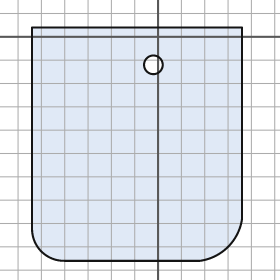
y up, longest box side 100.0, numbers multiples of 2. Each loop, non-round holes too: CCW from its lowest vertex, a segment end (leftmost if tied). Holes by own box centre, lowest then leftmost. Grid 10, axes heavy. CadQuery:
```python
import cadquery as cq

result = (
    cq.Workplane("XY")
    .moveTo(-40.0, -96.0)
    .lineTo(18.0, -96.0)
    .threePointArc((30.0, -90.0), (36.0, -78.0))
    .lineTo(36.0, 4.0)
    .lineTo(-54.0, 4.0)
    .lineTo(-54.0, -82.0)
    .threePointArc((-50.0, -92.0), (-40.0, -96.0))
    .close()
    .moveTo(-2.0, -12.0)
    .circle(4.0)
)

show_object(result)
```